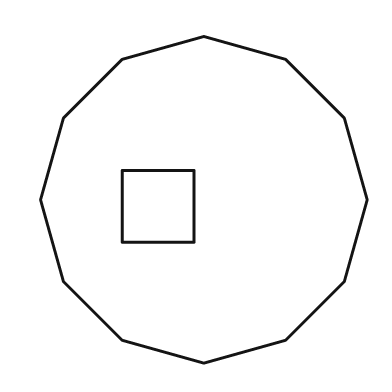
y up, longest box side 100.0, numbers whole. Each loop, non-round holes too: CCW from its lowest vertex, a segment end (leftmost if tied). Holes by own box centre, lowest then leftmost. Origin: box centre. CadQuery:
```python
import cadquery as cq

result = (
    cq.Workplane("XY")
    .moveTo(0.0, -50.0)
    .lineTo(25.0, -43.0)
    .lineTo(43.0, -25.0)
    .lineTo(50.0, 0.0)
    .lineTo(43.0, 25.0)
    .lineTo(25.0, 43.0)
    .lineTo(0.0, 50.0)
    .lineTo(-25.0, 43.0)
    .lineTo(-43.0, 25.0)
    .lineTo(-50.0, 0.0)
    .lineTo(-43.0, -25.0)
    .lineTo(-25.0, -43.0)
    .close()
    .moveTo(-25.0, -13.0)
    .lineTo(-3.0, -13.0)
    .lineTo(-3.0, 9.0)
    .lineTo(-25.0, 9.0)
    .close()
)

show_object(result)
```